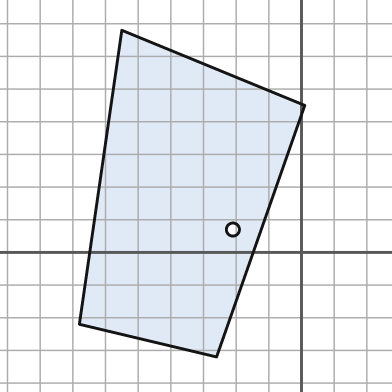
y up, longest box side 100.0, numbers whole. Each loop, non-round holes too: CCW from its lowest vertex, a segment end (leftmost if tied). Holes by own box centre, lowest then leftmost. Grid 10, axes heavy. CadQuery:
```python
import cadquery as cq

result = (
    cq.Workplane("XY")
    .moveTo(-26.0, -32.0)
    .lineTo(1.0, 45.0)
    .lineTo(-55.0, 68.0)
    .lineTo(-68.0, -22.0)
    .close()
    .moveTo(-21.0, 7.0)
    .circle(2.0)
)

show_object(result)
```